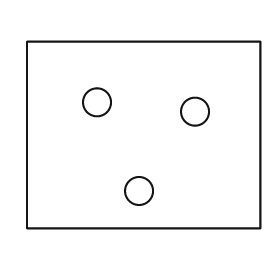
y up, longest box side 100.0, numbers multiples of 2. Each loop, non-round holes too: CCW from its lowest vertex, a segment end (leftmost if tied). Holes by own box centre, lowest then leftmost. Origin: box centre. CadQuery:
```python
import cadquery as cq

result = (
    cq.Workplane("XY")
    .moveTo(-50.0, -40.0)
    .lineTo(50.0, -40.0)
    .lineTo(50.0, 40.0)
    .lineTo(-50.0, 40.0)
    .close()
    .moveTo(-2.0, -24.0)
    .circle(6.0)
    .moveTo(22.0, 10.0)
    .circle(6.0)
    .moveTo(-20.0, 14.0)
    .circle(6.0)
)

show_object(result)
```